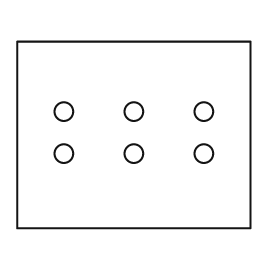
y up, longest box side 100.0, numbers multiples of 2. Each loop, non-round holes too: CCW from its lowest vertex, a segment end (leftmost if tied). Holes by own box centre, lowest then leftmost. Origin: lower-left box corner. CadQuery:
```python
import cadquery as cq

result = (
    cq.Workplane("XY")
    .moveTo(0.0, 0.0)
    .lineTo(100.0, 0.0)
    .lineTo(100.0, 80.0)
    .lineTo(0.0, 80.0)
    .close()
    .moveTo(20.0, 32.0)
    .circle(4.0)
    .moveTo(50.0, 32.0)
    .circle(4.0)
    .moveTo(80.0, 32.0)
    .circle(4.0)
    .moveTo(20.0, 50.0)
    .circle(4.0)
    .moveTo(50.0, 50.0)
    .circle(4.0)
    .moveTo(80.0, 50.0)
    .circle(4.0)
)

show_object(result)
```